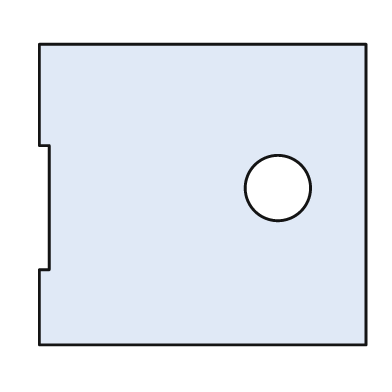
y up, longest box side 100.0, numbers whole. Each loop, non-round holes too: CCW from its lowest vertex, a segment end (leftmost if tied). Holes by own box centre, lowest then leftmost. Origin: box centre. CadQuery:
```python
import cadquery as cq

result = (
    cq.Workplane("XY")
    .moveTo(-50.0, -46.0)
    .lineTo(50.0, -46.0)
    .lineTo(50.0, 46.0)
    .lineTo(-50.0, 46.0)
    .lineTo(-50.0, 15.0)
    .lineTo(-47.0, 15.0)
    .lineTo(-47.0, -23.0)
    .lineTo(-50.0, -23.0)
    .close()
    .moveTo(23.0, 2.0)
    .circle(10.0)
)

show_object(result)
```